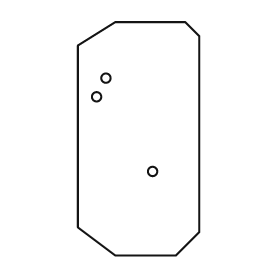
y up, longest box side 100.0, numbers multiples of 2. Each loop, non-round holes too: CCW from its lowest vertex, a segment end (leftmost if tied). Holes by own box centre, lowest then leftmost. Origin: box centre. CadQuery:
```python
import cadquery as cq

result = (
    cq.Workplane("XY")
    .moveTo(-10.0, -50.0)
    .lineTo(16.0, -50.0)
    .lineTo(26.0, -40.0)
    .lineTo(26.0, 44.0)
    .lineTo(20.0, 50.0)
    .lineTo(-10.0, 50.0)
    .lineTo(-26.0, 40.0)
    .lineTo(-26.0, -38.0)
    .close()
    .moveTo(6.0, -14.0)
    .circle(2.0)
    .moveTo(-18.0, 18.0)
    .circle(2.0)
    .moveTo(-14.0, 26.0)
    .circle(2.0)
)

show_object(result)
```